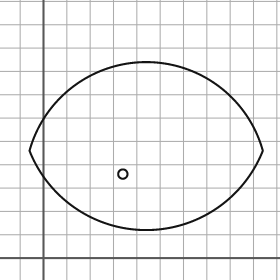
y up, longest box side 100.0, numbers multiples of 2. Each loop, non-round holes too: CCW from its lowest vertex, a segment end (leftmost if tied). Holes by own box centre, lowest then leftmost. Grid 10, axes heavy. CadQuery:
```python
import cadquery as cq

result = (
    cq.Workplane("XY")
    .moveTo(-6.0, 46.0)
    .threePointArc((44.0, 12.0), (94.0, 46.0))
    .threePointArc((44.0, 84.0), (-6.0, 46.0))
    .close()
    .moveTo(34.0, 36.0)
    .circle(2.0)
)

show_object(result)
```